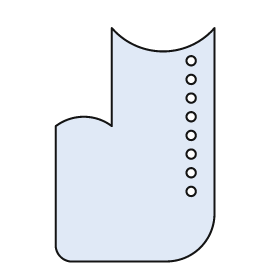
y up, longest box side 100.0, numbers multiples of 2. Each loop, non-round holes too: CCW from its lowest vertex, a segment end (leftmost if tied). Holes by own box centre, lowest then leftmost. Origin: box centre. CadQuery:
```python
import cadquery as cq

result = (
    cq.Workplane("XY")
    .moveTo(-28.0, -50.0)
    .lineTo(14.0, -50.0)
    .threePointArc((28.0, -44.0), (34.0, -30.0))
    .lineTo(34.0, 50.0)
    .threePointArc((12.0, 40.0), (-10.0, 50.0))
    .lineTo(-10.0, 8.0)
    .threePointArc((-22.0, 12.0), (-34.0, 8.0))
    .lineTo(-34.0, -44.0)
    .threePointArc((-32.0, -48.0), (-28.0, -50.0))
    .close()
    .moveTo(24.0, -20.0)
    .circle(2.0)
    .moveTo(24.0, -12.0)
    .circle(2.0)
    .moveTo(24.0, -4.0)
    .circle(2.0)
    .moveTo(24.0, 4.0)
    .circle(2.0)
    .moveTo(24.0, 12.0)
    .circle(2.0)
    .moveTo(24.0, 20.0)
    .circle(2.0)
    .moveTo(24.0, 28.0)
    .circle(2.0)
    .moveTo(24.0, 36.0)
    .circle(2.0)
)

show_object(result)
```